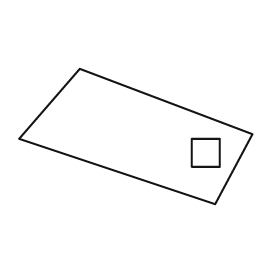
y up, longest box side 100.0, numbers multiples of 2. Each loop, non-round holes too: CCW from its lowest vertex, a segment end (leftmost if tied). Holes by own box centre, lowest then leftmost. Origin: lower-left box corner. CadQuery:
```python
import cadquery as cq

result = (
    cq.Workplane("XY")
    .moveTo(84.0, 0.0)
    .lineTo(100.0, 30.0)
    .lineTo(26.0, 58.0)
    .lineTo(0.0, 28.0)
    .close()
    .moveTo(74.0, 16.0)
    .lineTo(86.0, 16.0)
    .lineTo(86.0, 28.0)
    .lineTo(74.0, 28.0)
    .close()
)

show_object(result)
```